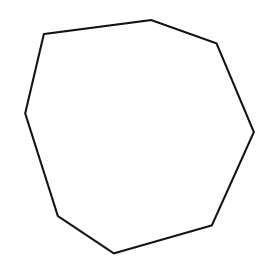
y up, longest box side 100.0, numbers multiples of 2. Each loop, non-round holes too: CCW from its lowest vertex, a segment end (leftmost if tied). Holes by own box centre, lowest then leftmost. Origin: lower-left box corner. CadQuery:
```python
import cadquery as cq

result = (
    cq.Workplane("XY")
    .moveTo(38.0, 0.0)
    .lineTo(80.0, 12.0)
    .lineTo(98.0, 52.0)
    .lineTo(82.0, 90.0)
    .lineTo(54.0, 100.0)
    .lineTo(8.0, 94.0)
    .lineTo(0.0, 60.0)
    .lineTo(14.0, 16.0)
    .close()
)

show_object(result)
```